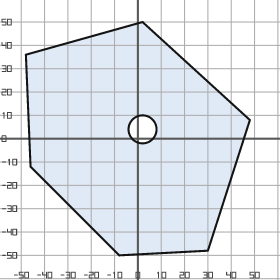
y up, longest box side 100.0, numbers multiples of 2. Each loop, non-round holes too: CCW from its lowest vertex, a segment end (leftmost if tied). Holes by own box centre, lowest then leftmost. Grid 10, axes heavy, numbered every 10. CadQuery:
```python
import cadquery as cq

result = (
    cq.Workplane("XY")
    .moveTo(-8.0, -50.0)
    .lineTo(30.0, -48.0)
    .lineTo(48.0, 8.0)
    .lineTo(2.0, 50.0)
    .lineTo(-48.0, 36.0)
    .lineTo(-46.0, -12.0)
    .close()
    .moveTo(2.0, 4.0)
    .circle(6.0)
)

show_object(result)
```